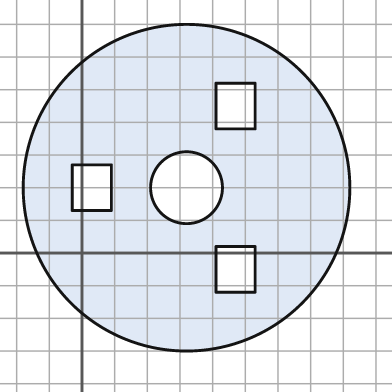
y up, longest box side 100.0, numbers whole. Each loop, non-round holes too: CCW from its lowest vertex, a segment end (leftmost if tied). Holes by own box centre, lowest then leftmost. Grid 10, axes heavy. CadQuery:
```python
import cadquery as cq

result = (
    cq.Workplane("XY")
    .moveTo(32.0, 20.0)
    .circle(50.0)
    .moveTo(41.0, -12.0)
    .lineTo(53.0, -12.0)
    .lineTo(53.0, 2.0)
    .lineTo(41.0, 2.0)
    .close()
    .moveTo(-3.0, 13.0)
    .lineTo(9.0, 13.0)
    .lineTo(9.0, 27.0)
    .lineTo(-3.0, 27.0)
    .close()
    .moveTo(32.0, 20.0)
    .circle(11.0)
    .moveTo(41.0, 38.0)
    .lineTo(53.0, 38.0)
    .lineTo(53.0, 52.0)
    .lineTo(41.0, 52.0)
    .close()
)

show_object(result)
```